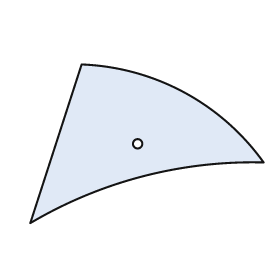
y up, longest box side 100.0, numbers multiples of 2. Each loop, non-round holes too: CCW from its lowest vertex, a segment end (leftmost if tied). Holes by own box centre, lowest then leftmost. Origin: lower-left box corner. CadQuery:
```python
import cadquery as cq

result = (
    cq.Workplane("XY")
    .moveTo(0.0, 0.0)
    .threePointArc((48.0, 20.0), (100.0, 26.0))
    .threePointArc((66.0, 56.0), (22.0, 68.0))
    .close()
    .moveTo(46.0, 34.0)
    .circle(2.0)
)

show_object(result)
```